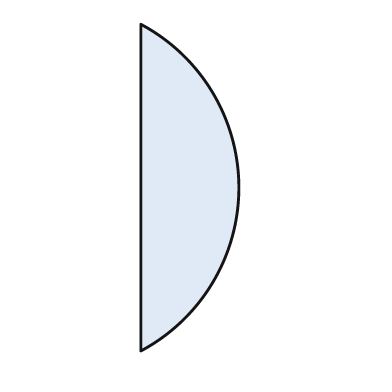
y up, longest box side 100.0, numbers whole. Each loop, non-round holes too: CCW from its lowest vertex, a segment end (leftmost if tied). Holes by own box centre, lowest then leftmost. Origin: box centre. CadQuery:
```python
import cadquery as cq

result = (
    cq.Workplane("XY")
    .moveTo(-15.0, -50.0)
    .threePointArc((15.0, 0.0), (-15.0, 50.0))
    .close()
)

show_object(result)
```